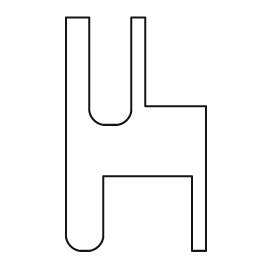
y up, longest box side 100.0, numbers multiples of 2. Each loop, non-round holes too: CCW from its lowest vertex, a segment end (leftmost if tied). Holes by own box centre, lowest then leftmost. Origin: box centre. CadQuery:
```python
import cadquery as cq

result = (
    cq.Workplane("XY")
    .moveTo(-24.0, -50.0)
    .lineTo(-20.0, -50.0)
    .threePointArc((-16.0, -48.0), (-14.0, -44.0))
    .lineTo(-14.0, -18.0)
    .lineTo(24.0, -18.0)
    .lineTo(24.0, -50.0)
    .lineTo(30.0, -50.0)
    .lineTo(30.0, 12.0)
    .lineTo(4.0, 12.0)
    .lineTo(4.0, 50.0)
    .lineTo(-2.0, 50.0)
    .lineTo(-2.0, 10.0)
    .threePointArc((-4.0, 6.0), (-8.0, 4.0))
    .lineTo(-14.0, 4.0)
    .threePointArc((-18.0, 6.0), (-20.0, 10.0))
    .lineTo(-20.0, 50.0)
    .lineTo(-30.0, 50.0)
    .lineTo(-30.0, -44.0)
    .threePointArc((-28.0, -48.0), (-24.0, -50.0))
    .close()
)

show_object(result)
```